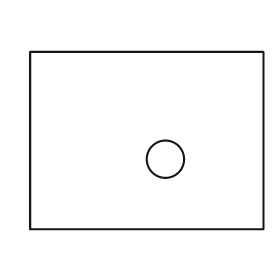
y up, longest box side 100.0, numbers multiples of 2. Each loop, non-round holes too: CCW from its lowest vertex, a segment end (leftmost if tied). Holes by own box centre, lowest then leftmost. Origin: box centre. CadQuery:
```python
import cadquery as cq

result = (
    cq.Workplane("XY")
    .moveTo(-50.0, -38.0)
    .lineTo(50.0, -38.0)
    .lineTo(50.0, 38.0)
    .lineTo(-50.0, 38.0)
    .close()
    .moveTo(8.0, -8.0)
    .circle(8.0)
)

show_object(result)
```